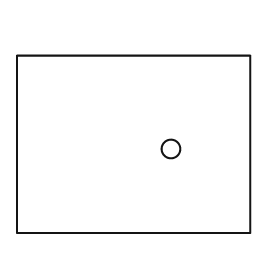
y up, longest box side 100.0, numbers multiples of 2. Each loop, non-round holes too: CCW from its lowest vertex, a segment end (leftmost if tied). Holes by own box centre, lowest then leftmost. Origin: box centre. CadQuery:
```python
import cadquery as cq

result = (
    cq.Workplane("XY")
    .moveTo(-50.0, -38.0)
    .lineTo(50.0, -38.0)
    .lineTo(50.0, 38.0)
    .lineTo(-50.0, 38.0)
    .close()
    .moveTo(16.0, -2.0)
    .circle(4.0)
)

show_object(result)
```